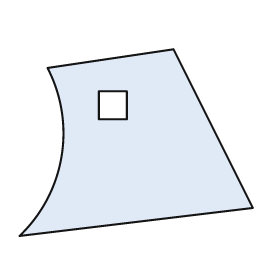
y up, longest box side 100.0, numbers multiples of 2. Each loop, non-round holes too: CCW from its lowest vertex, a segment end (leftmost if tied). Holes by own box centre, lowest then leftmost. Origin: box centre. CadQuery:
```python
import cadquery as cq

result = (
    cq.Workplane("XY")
    .moveTo(-50.0, -40.0)
    .lineTo(50.0, -28.0)
    .lineTo(16.0, 40.0)
    .lineTo(-38.0, 32.0)
    .threePointArc((-32.0, -6.0), (-50.0, -40.0))
    .close()
    .moveTo(-16.0, 10.0)
    .lineTo(-4.0, 10.0)
    .lineTo(-4.0, 22.0)
    .lineTo(-16.0, 22.0)
    .close()
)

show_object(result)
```